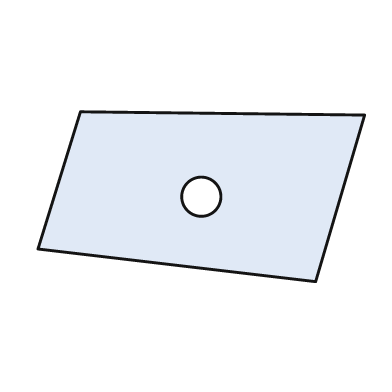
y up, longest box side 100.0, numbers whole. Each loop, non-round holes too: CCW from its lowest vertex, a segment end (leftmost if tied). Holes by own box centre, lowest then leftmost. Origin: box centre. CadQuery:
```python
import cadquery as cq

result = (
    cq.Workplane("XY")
    .moveTo(35.0, -26.0)
    .lineTo(50.0, 25.0)
    .lineTo(-37.0, 26.0)
    .lineTo(-50.0, -16.0)
    .close()
    .moveTo(0.0, 0.0)
    .circle(6.0)
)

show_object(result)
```